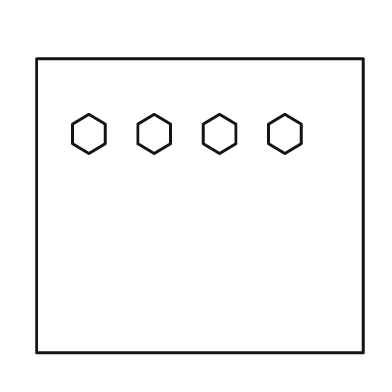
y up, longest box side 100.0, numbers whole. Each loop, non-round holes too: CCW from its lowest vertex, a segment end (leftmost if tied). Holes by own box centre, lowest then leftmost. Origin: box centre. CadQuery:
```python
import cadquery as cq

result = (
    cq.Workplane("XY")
    .moveTo(-50.0, -45.0)
    .lineTo(50.0, -45.0)
    .lineTo(50.0, 45.0)
    .lineTo(-50.0, 45.0)
    .close()
    .moveTo(-34.0, 16.0)
    .lineTo(-29.0, 19.0)
    .lineTo(-29.0, 25.0)
    .lineTo(-34.0, 28.0)
    .lineTo(-39.0, 25.0)
    .lineTo(-39.0, 19.0)
    .close()
    .moveTo(-14.0, 16.0)
    .lineTo(-9.0, 19.0)
    .lineTo(-9.0, 25.0)
    .lineTo(-14.0, 28.0)
    .lineTo(-19.0, 25.0)
    .lineTo(-19.0, 19.0)
    .close()
    .moveTo(6.0, 16.0)
    .lineTo(11.0, 19.0)
    .lineTo(11.0, 25.0)
    .lineTo(6.0, 28.0)
    .lineTo(1.0, 25.0)
    .lineTo(1.0, 19.0)
    .close()
    .moveTo(26.0, 16.0)
    .lineTo(31.0, 19.0)
    .lineTo(31.0, 25.0)
    .lineTo(26.0, 28.0)
    .lineTo(21.0, 25.0)
    .lineTo(21.0, 19.0)
    .close()
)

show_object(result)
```